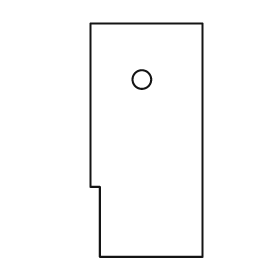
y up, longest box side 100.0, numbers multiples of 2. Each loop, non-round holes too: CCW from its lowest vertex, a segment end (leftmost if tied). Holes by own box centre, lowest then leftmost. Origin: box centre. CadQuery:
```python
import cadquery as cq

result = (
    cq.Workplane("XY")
    .moveTo(-20.0, -50.0)
    .lineTo(24.0, -50.0)
    .lineTo(24.0, 50.0)
    .lineTo(-24.0, 50.0)
    .lineTo(-24.0, -20.0)
    .lineTo(-20.0, -20.0)
    .close()
    .moveTo(-2.0, 26.0)
    .circle(4.0)
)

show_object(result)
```